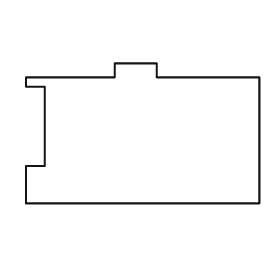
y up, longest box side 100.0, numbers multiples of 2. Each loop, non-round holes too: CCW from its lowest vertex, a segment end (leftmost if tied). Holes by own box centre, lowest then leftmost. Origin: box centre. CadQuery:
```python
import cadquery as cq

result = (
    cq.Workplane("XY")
    .moveTo(-50.0, -30.0)
    .lineTo(50.0, -30.0)
    .lineTo(50.0, 24.0)
    .lineTo(6.0, 24.0)
    .lineTo(6.0, 30.0)
    .lineTo(-12.0, 30.0)
    .lineTo(-12.0, 24.0)
    .lineTo(-50.0, 24.0)
    .lineTo(-50.0, 20.0)
    .lineTo(-42.0, 20.0)
    .lineTo(-42.0, -14.0)
    .lineTo(-50.0, -14.0)
    .close()
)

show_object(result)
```